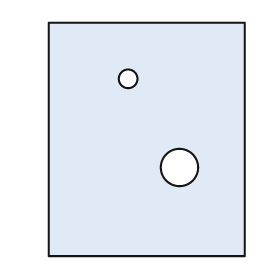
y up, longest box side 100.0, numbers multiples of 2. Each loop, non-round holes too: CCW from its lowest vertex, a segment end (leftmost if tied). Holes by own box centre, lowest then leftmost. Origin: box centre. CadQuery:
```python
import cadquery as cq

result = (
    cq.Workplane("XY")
    .moveTo(-42.0, -50.0)
    .lineTo(42.0, -50.0)
    .lineTo(42.0, 50.0)
    .lineTo(-42.0, 50.0)
    .close()
    .moveTo(14.0, -12.0)
    .circle(8.0)
    .moveTo(-8.0, 26.0)
    .circle(4.0)
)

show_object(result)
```